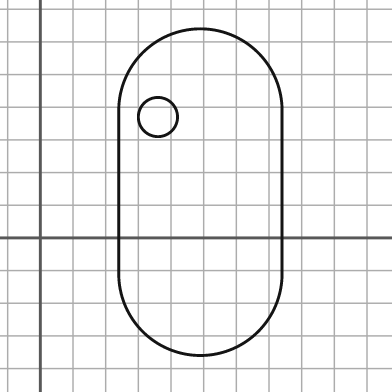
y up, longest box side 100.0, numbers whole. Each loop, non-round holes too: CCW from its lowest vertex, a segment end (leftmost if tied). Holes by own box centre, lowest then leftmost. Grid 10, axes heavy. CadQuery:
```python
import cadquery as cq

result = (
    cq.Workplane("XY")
    .moveTo(24.0, -11.0)
    .threePointArc((49.0, -36.0), (74.0, -11.0))
    .lineTo(74.0, 39.0)
    .threePointArc((49.0, 64.0), (24.0, 39.0))
    .close()
    .moveTo(36.0, 37.0)
    .circle(6.0)
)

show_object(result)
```